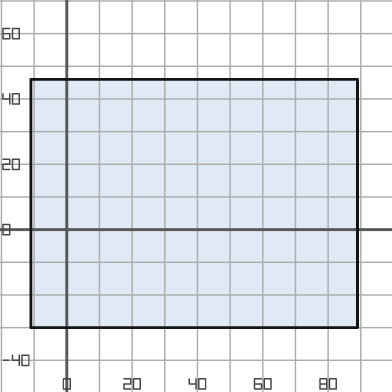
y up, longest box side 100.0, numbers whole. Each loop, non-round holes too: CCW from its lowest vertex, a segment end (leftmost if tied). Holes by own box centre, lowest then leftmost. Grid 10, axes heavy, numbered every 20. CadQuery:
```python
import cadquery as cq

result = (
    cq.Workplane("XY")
    .moveTo(-11.0, -30.0)
    .lineTo(89.0, -30.0)
    .lineTo(89.0, 46.0)
    .lineTo(-11.0, 46.0)
    .close()
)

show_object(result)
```